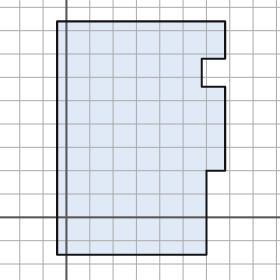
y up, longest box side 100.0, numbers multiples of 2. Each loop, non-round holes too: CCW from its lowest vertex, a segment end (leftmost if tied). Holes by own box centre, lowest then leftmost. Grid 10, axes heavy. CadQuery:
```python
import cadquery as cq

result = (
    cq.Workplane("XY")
    .moveTo(-4.0, -16.0)
    .lineTo(60.0, -16.0)
    .lineTo(60.0, 20.0)
    .lineTo(68.0, 20.0)
    .lineTo(68.0, 56.0)
    .lineTo(58.0, 56.0)
    .lineTo(58.0, 68.0)
    .lineTo(68.0, 68.0)
    .lineTo(68.0, 84.0)
    .lineTo(-4.0, 84.0)
    .close()
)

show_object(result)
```